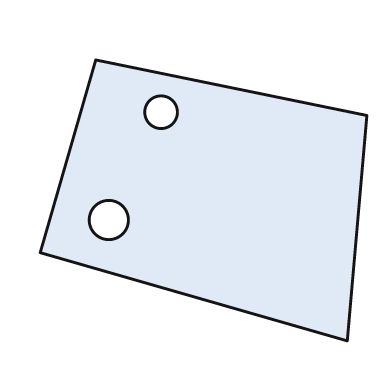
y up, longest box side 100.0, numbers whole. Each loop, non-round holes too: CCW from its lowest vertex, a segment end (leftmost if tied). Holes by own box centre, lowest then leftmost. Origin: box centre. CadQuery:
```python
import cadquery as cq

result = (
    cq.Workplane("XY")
    .moveTo(44.0, -43.0)
    .lineTo(50.0, 26.0)
    .lineTo(-33.0, 43.0)
    .lineTo(-50.0, -16.0)
    .close()
    .moveTo(-29.0, -6.0)
    .circle(6.0)
    .moveTo(-13.0, 27.0)
    .circle(5.0)
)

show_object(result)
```